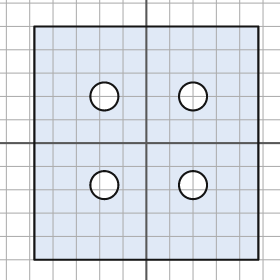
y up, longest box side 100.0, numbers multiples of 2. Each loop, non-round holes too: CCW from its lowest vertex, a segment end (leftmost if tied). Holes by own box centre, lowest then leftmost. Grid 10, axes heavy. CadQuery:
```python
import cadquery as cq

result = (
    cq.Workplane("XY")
    .moveTo(-48.0, -50.0)
    .lineTo(48.0, -50.0)
    .lineTo(48.0, 50.0)
    .lineTo(-48.0, 50.0)
    .close()
    .moveTo(-18.0, -18.0)
    .circle(6.0)
    .moveTo(20.0, -18.0)
    .circle(6.0)
    .moveTo(-18.0, 20.0)
    .circle(6.0)
    .moveTo(20.0, 20.0)
    .circle(6.0)
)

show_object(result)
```